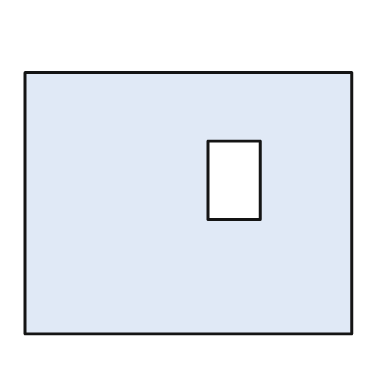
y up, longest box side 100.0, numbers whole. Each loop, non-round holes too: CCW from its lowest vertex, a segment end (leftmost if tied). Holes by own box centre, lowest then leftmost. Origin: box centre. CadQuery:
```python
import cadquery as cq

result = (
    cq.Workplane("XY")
    .moveTo(-50.0, -40.0)
    .lineTo(50.0, -40.0)
    .lineTo(50.0, 40.0)
    .lineTo(-50.0, 40.0)
    .close()
    .moveTo(6.0, -5.0)
    .lineTo(22.0, -5.0)
    .lineTo(22.0, 19.0)
    .lineTo(6.0, 19.0)
    .close()
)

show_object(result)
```